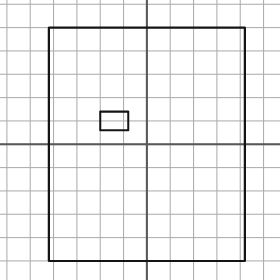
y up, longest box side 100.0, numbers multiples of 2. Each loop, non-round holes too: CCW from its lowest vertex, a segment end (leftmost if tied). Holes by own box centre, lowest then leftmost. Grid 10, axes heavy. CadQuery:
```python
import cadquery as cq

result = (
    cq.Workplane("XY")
    .moveTo(-42.0, -50.0)
    .lineTo(42.0, -50.0)
    .lineTo(42.0, 50.0)
    .lineTo(-42.0, 50.0)
    .close()
    .moveTo(-20.0, 6.0)
    .lineTo(-8.0, 6.0)
    .lineTo(-8.0, 14.0)
    .lineTo(-20.0, 14.0)
    .close()
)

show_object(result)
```